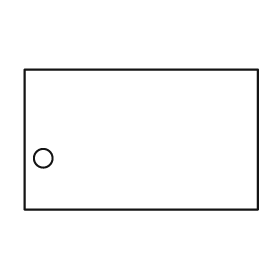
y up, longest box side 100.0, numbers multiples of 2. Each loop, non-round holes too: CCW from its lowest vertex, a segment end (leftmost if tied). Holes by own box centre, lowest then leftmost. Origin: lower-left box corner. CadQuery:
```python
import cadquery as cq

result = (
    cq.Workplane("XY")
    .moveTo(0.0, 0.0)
    .lineTo(100.0, 0.0)
    .lineTo(100.0, 60.0)
    .lineTo(0.0, 60.0)
    .close()
    .moveTo(8.0, 22.0)
    .circle(4.0)
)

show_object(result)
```